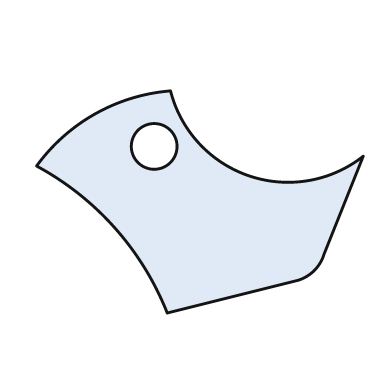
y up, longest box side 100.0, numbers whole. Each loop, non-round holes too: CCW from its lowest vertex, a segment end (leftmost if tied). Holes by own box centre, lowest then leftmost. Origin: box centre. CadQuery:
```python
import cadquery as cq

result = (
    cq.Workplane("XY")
    .moveTo(-10.0, -34.0)
    .lineTo(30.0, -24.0)
    .threePointArc((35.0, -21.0), (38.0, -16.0))
    .lineTo(50.0, 14.0)
    .threePointArc((15.0, 8.0), (-9.0, 34.0))
    .threePointArc((-32.0, 27.0), (-50.0, 11.0))
    .threePointArc((-26.0, -8.0), (-10.0, -34.0))
    .close()
    .moveTo(-14.0, 17.0)
    .circle(7.0)
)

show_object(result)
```